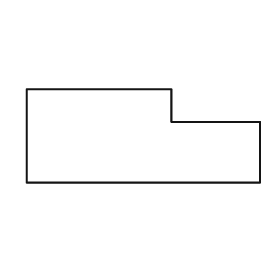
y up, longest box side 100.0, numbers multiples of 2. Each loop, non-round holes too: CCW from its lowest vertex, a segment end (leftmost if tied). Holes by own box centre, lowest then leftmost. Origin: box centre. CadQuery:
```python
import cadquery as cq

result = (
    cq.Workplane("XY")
    .moveTo(-50.0, -20.0)
    .lineTo(50.0, -20.0)
    .lineTo(50.0, 6.0)
    .lineTo(12.0, 6.0)
    .lineTo(12.0, 20.0)
    .lineTo(-50.0, 20.0)
    .close()
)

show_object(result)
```